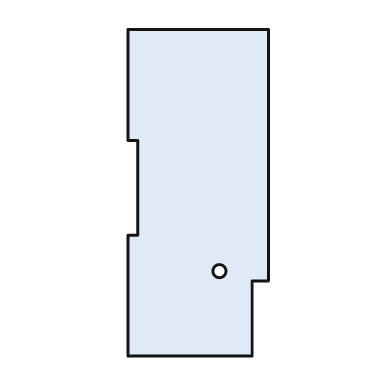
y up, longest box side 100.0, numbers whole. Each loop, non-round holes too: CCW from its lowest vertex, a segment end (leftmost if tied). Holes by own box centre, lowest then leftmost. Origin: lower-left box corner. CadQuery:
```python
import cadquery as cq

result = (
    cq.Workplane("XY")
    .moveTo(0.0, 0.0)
    .lineTo(38.0, 0.0)
    .lineTo(38.0, 23.0)
    .lineTo(43.0, 23.0)
    .lineTo(43.0, 100.0)
    .lineTo(0.0, 100.0)
    .lineTo(0.0, 66.0)
    .lineTo(3.0, 66.0)
    .lineTo(3.0, 37.0)
    .lineTo(0.0, 37.0)
    .close()
    .moveTo(28.0, 26.0)
    .circle(2.0)
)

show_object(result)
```